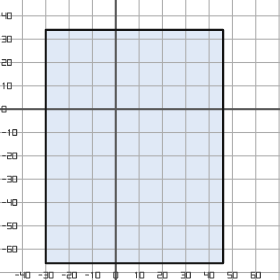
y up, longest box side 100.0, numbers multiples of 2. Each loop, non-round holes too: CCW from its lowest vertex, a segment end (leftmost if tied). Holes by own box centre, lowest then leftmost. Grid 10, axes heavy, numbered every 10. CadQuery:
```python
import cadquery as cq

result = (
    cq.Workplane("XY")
    .moveTo(-30.0, -66.0)
    .lineTo(46.0, -66.0)
    .lineTo(46.0, 34.0)
    .lineTo(-30.0, 34.0)
    .close()
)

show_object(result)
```